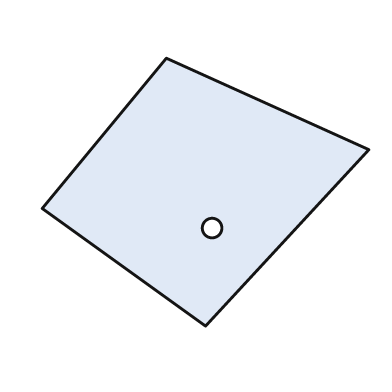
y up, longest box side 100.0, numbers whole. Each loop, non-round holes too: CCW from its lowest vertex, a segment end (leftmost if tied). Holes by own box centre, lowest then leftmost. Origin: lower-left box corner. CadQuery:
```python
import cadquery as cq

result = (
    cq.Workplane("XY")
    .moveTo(50.0, 0.0)
    .lineTo(100.0, 54.0)
    .lineTo(38.0, 82.0)
    .lineTo(0.0, 36.0)
    .close()
    .moveTo(52.0, 30.0)
    .circle(3.0)
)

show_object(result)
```